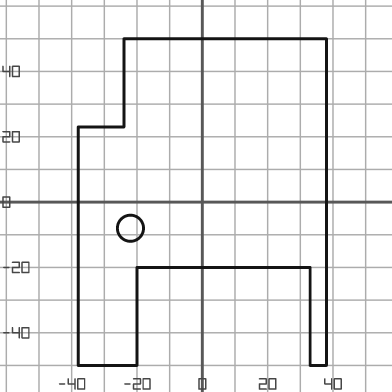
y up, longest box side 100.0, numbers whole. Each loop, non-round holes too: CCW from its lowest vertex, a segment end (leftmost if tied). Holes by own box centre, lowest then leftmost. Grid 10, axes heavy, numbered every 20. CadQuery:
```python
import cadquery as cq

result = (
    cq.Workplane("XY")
    .moveTo(-38.0, -50.0)
    .lineTo(-20.0, -50.0)
    .lineTo(-20.0, -20.0)
    .lineTo(33.0, -20.0)
    .lineTo(33.0, -50.0)
    .lineTo(38.0, -50.0)
    .lineTo(38.0, 50.0)
    .lineTo(-24.0, 50.0)
    .lineTo(-24.0, 23.0)
    .lineTo(-38.0, 23.0)
    .close()
    .moveTo(-22.0, -8.0)
    .circle(4.0)
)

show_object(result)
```